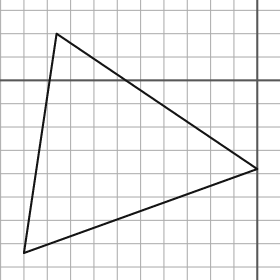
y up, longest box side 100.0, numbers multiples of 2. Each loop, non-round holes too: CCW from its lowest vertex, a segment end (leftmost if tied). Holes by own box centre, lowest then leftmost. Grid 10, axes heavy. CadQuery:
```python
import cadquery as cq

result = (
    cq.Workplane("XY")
    .moveTo(-100.0, -74.0)
    .lineTo(0.0, -38.0)
    .lineTo(-86.0, 20.0)
    .close()
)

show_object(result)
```